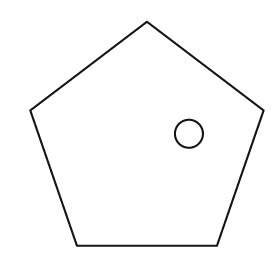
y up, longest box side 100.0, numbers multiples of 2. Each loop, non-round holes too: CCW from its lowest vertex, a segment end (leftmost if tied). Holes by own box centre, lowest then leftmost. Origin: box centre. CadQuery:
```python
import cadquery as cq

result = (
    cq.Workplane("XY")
    .moveTo(-30.0, -48.0)
    .lineTo(30.0, -48.0)
    .lineTo(50.0, 10.0)
    .lineTo(0.0, 48.0)
    .lineTo(-50.0, 10.0)
    .close()
    .moveTo(18.0, 0.0)
    .circle(6.0)
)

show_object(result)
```